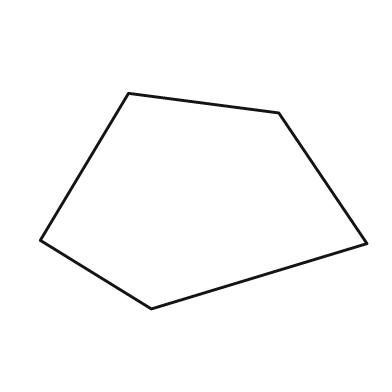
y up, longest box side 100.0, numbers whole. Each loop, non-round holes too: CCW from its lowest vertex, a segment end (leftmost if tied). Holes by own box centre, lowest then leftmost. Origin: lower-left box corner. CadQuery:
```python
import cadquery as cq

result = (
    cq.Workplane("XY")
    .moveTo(34.0, 0.0)
    .lineTo(100.0, 20.0)
    .lineTo(73.0, 60.0)
    .lineTo(27.0, 66.0)
    .lineTo(0.0, 21.0)
    .close()
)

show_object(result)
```